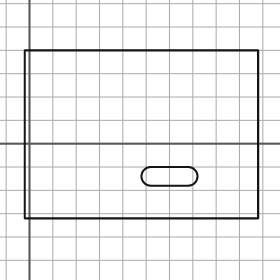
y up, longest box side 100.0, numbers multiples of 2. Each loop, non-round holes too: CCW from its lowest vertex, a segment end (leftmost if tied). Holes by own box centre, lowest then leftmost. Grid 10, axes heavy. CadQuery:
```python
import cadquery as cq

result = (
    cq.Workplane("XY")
    .moveTo(-2.0, -32.0)
    .lineTo(98.0, -32.0)
    .lineTo(98.0, 40.0)
    .lineTo(-2.0, 40.0)
    .close()
    .moveTo(52.0, -18.0)
    .lineTo(68.0, -18.0)
    .threePointArc((72.0, -14.0), (68.0, -10.0))
    .lineTo(52.0, -10.0)
    .threePointArc((48.0, -14.0), (52.0, -18.0))
    .close()
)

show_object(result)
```